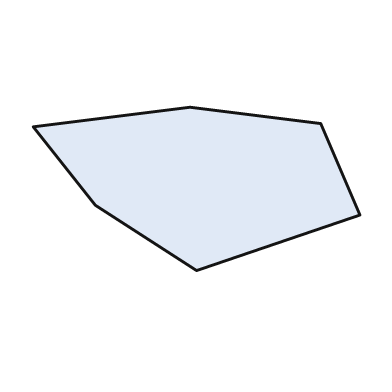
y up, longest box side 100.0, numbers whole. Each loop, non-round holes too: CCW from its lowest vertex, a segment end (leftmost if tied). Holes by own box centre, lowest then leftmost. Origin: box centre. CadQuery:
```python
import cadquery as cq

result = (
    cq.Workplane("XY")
    .moveTo(0.0, -25.0)
    .lineTo(50.0, -8.0)
    .lineTo(38.0, 20.0)
    .lineTo(-2.0, 25.0)
    .lineTo(-50.0, 19.0)
    .lineTo(-31.0, -5.0)
    .close()
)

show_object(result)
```